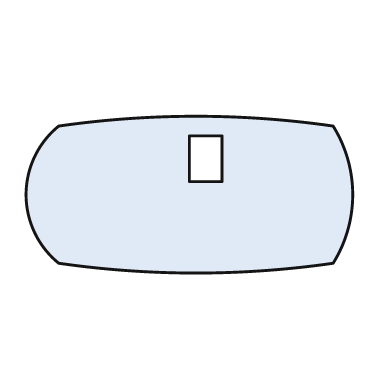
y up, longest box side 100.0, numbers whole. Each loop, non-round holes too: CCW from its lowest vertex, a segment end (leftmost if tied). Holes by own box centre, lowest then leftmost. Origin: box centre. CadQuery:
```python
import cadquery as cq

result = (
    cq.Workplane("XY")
    .moveTo(-40.0, -21.0)
    .threePointArc((2.0, -24.0), (44.0, -21.0))
    .threePointArc((50.0, 0.0), (44.0, 21.0))
    .threePointArc((2.0, 24.0), (-40.0, 21.0))
    .threePointArc((-50.0, 0.0), (-40.0, -21.0))
    .close()
    .moveTo(0.0, 4.0)
    .lineTo(10.0, 4.0)
    .lineTo(10.0, 18.0)
    .lineTo(0.0, 18.0)
    .close()
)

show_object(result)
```